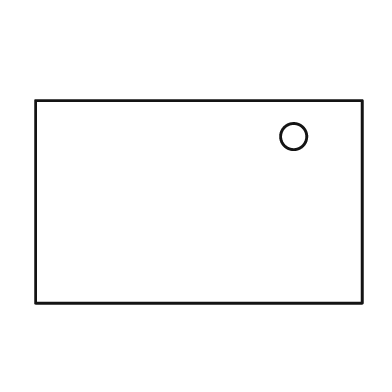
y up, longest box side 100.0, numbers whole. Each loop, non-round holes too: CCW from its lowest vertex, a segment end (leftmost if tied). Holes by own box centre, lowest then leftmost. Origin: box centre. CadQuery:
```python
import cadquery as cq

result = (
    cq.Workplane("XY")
    .moveTo(-50.0, -31.0)
    .lineTo(50.0, -31.0)
    .lineTo(50.0, 31.0)
    .lineTo(-50.0, 31.0)
    .close()
    .moveTo(29.0, 20.0)
    .circle(4.0)
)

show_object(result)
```